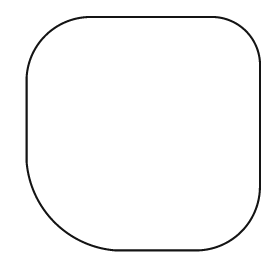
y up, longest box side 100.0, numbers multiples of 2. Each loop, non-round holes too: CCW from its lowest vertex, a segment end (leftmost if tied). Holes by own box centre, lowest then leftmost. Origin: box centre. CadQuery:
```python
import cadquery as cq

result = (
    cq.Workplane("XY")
    .moveTo(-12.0, -50.0)
    .lineTo(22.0, -50.0)
    .threePointArc((42.0, -42.0), (50.0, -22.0))
    .lineTo(50.0, 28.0)
    .threePointArc((44.0, 44.0), (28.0, 50.0))
    .lineTo(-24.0, 50.0)
    .threePointArc((-42.0, 42.0), (-50.0, 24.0))
    .lineTo(-50.0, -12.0)
    .threePointArc((-38.0, -38.0), (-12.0, -50.0))
    .close()
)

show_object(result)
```